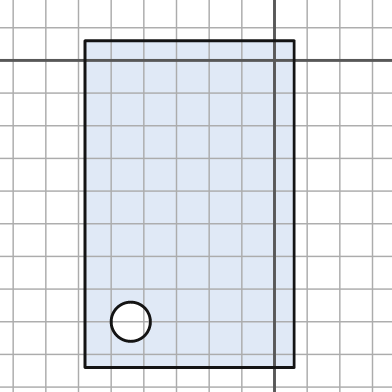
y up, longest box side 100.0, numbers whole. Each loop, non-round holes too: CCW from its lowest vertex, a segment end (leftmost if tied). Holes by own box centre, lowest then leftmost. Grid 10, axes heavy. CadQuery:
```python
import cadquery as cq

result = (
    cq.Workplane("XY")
    .moveTo(-58.0, -94.0)
    .lineTo(6.0, -94.0)
    .lineTo(6.0, 6.0)
    .lineTo(-58.0, 6.0)
    .close()
    .moveTo(-44.0, -80.0)
    .circle(6.0)
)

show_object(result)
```